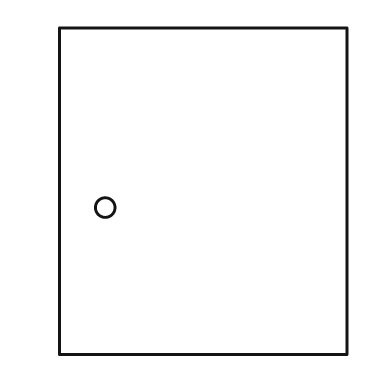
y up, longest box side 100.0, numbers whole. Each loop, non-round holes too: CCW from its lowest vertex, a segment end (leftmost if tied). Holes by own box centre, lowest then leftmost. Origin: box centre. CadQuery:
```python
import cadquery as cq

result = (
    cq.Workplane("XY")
    .moveTo(-44.0, -50.0)
    .lineTo(44.0, -50.0)
    .lineTo(44.0, 50.0)
    .lineTo(-44.0, 50.0)
    .close()
    .moveTo(-30.0, -5.0)
    .circle(3.0)
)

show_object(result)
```